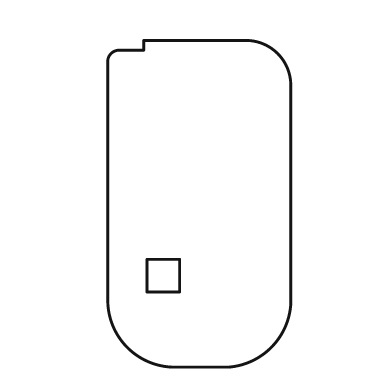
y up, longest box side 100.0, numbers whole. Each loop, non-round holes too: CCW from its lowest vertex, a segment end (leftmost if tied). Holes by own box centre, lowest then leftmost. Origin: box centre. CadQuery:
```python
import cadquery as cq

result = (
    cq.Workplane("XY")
    .moveTo(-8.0, -50.0)
    .lineTo(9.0, -50.0)
    .threePointArc((22.0, -44.0), (28.0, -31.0))
    .lineTo(28.0, 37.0)
    .threePointArc((24.0, 46.0), (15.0, 50.0))
    .lineTo(-17.0, 50.0)
    .lineTo(-17.0, 47.0)
    .lineTo(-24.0, 47.0)
    .threePointArc((-27.0, 46.0), (-28.0, 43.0))
    .lineTo(-28.0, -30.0)
    .threePointArc((-22.0, -44.0), (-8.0, -50.0))
    .close()
    .moveTo(-16.0, -27.0)
    .lineTo(-6.0, -27.0)
    .lineTo(-6.0, -17.0)
    .lineTo(-16.0, -17.0)
    .close()
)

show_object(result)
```